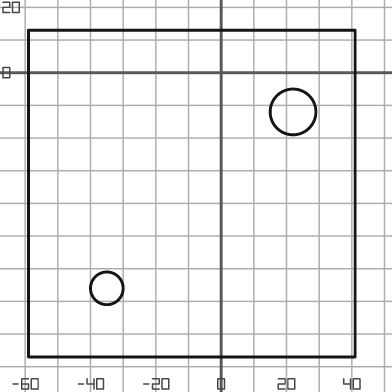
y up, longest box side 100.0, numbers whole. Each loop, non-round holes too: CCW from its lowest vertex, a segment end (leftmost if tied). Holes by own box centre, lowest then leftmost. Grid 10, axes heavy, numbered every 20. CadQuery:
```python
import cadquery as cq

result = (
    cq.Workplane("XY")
    .moveTo(-59.0, -87.0)
    .lineTo(41.0, -87.0)
    .lineTo(41.0, 13.0)
    .lineTo(-59.0, 13.0)
    .close()
    .moveTo(-35.0, -66.0)
    .circle(5.0)
    .moveTo(22.0, -12.0)
    .circle(7.0)
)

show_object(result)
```